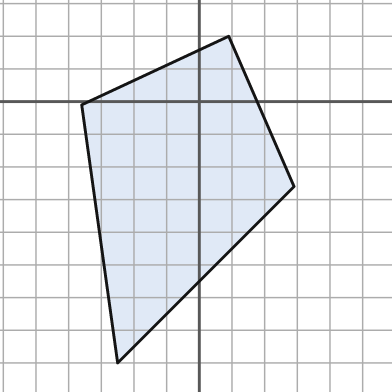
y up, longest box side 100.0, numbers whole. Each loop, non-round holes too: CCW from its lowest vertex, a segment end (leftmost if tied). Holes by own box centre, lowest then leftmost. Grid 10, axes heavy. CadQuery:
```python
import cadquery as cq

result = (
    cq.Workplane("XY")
    .moveTo(-25.0, -80.0)
    .lineTo(29.0, -26.0)
    .lineTo(9.0, 20.0)
    .lineTo(-36.0, -1.0)
    .close()
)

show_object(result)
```